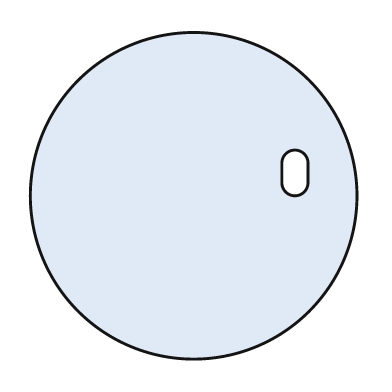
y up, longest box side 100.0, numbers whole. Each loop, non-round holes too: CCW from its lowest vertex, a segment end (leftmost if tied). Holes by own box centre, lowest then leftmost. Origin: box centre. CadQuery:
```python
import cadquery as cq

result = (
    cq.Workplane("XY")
    .moveTo(0.0, 0.0)
    .circle(50.0)
    .moveTo(27.0, 4.0)
    .threePointArc((31.0, 0.0), (35.0, 4.0))
    .lineTo(35.0, 10.0)
    .threePointArc((31.0, 14.0), (27.0, 10.0))
    .close()
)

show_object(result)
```